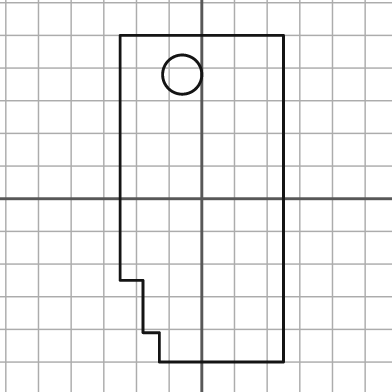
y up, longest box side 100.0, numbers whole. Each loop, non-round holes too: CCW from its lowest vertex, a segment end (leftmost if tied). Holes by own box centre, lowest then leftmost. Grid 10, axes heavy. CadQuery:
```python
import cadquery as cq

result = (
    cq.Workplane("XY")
    .moveTo(-13.0, -50.0)
    .lineTo(25.0, -50.0)
    .lineTo(25.0, 50.0)
    .lineTo(-25.0, 50.0)
    .lineTo(-25.0, -25.0)
    .lineTo(-18.0, -25.0)
    .lineTo(-18.0, -41.0)
    .lineTo(-13.0, -41.0)
    .close()
    .moveTo(-6.0, 38.0)
    .circle(6.0)
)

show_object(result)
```